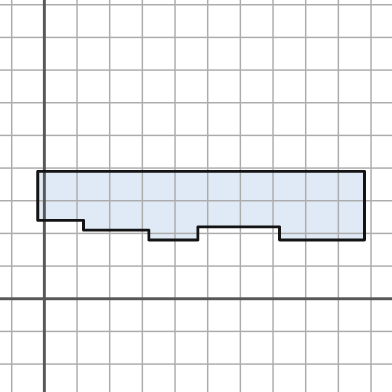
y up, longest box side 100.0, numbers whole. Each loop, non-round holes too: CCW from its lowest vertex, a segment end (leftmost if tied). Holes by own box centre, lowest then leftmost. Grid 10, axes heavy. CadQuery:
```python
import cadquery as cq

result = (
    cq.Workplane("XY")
    .moveTo(32.0, 18.0)
    .lineTo(47.0, 18.0)
    .lineTo(47.0, 22.0)
    .lineTo(72.0, 22.0)
    .lineTo(72.0, 18.0)
    .lineTo(98.0, 18.0)
    .lineTo(98.0, 39.0)
    .lineTo(-2.0, 39.0)
    .lineTo(-2.0, 24.0)
    .lineTo(12.0, 24.0)
    .lineTo(12.0, 21.0)
    .lineTo(32.0, 21.0)
    .close()
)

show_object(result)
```